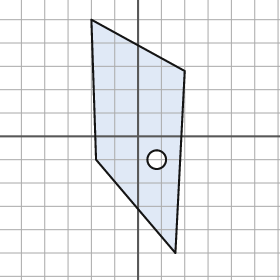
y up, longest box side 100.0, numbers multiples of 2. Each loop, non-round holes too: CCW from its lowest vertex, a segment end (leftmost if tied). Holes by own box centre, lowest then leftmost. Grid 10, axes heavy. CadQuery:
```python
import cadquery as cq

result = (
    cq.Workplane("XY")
    .moveTo(16.0, -50.0)
    .lineTo(20.0, 28.0)
    .lineTo(-20.0, 50.0)
    .lineTo(-18.0, -10.0)
    .close()
    .moveTo(8.0, -10.0)
    .circle(4.0)
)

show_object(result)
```